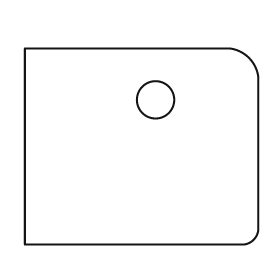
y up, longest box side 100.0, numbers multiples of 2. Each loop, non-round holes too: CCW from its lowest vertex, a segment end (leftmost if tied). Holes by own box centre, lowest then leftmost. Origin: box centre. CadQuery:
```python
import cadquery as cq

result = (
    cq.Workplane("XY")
    .moveTo(-50.0, -42.0)
    .lineTo(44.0, -42.0)
    .threePointArc((48.0, -40.0), (50.0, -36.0))
    .lineTo(50.0, 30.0)
    .threePointArc((46.0, 38.0), (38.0, 42.0))
    .lineTo(-50.0, 42.0)
    .close()
    .moveTo(6.0, 20.0)
    .circle(8.0)
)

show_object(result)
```